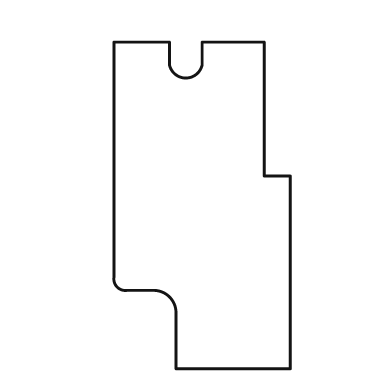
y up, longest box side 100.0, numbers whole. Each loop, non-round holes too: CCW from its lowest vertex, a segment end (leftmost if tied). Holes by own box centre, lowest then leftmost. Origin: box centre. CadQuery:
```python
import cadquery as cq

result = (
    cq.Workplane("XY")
    .moveTo(-8.0, -50.0)
    .lineTo(27.0, -50.0)
    .lineTo(27.0, 9.0)
    .lineTo(19.0, 9.0)
    .lineTo(19.0, 50.0)
    .lineTo(0.0, 50.0)
    .lineTo(0.0, 43.0)
    .threePointArc((-5.0, 39.0), (-10.0, 43.0))
    .lineTo(-10.0, 50.0)
    .lineTo(-27.0, 50.0)
    .lineTo(-27.0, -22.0)
    .threePointArc((-26.0, -25.0), (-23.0, -26.0))
    .lineTo(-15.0, -26.0)
    .threePointArc((-10.0, -28.0), (-8.0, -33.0))
    .close()
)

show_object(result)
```